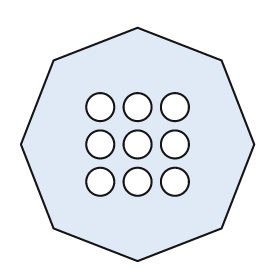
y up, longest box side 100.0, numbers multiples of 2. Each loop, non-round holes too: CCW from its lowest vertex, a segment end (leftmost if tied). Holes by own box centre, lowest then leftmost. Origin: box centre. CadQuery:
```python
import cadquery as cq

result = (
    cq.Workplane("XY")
    .moveTo(0.0, -50.0)
    .lineTo(36.0, -36.0)
    .lineTo(50.0, 0.0)
    .lineTo(36.0, 36.0)
    .lineTo(0.0, 50.0)
    .lineTo(-36.0, 36.0)
    .lineTo(-50.0, 0.0)
    .lineTo(-36.0, -36.0)
    .close()
    .moveTo(-16.0, -16.0)
    .circle(6.0)
    .moveTo(0.0, -16.0)
    .circle(6.0)
    .moveTo(16.0, -16.0)
    .circle(6.0)
    .moveTo(-16.0, 0.0)
    .circle(6.0)
    .moveTo(0.0, 0.0)
    .circle(6.0)
    .moveTo(16.0, 0.0)
    .circle(6.0)
    .moveTo(-16.0, 16.0)
    .circle(6.0)
    .moveTo(0.0, 16.0)
    .circle(6.0)
    .moveTo(16.0, 16.0)
    .circle(6.0)
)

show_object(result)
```